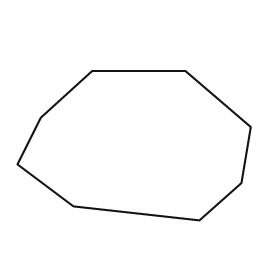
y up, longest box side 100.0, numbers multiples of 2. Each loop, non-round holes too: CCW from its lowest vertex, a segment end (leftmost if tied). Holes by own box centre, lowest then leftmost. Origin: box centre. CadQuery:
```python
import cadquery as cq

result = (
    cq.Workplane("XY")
    .moveTo(28.0, -32.0)
    .lineTo(46.0, -16.0)
    .lineTo(50.0, 8.0)
    .lineTo(22.0, 32.0)
    .lineTo(-18.0, 32.0)
    .lineTo(-40.0, 12.0)
    .lineTo(-50.0, -8.0)
    .lineTo(-26.0, -26.0)
    .close()
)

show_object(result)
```